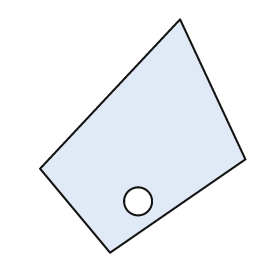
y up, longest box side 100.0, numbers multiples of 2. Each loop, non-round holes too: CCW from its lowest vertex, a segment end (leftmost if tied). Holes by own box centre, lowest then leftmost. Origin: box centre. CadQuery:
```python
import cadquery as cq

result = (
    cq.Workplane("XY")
    .moveTo(-14.0, -50.0)
    .lineTo(44.0, -10.0)
    .lineTo(16.0, 50.0)
    .lineTo(-44.0, -14.0)
    .close()
    .moveTo(-2.0, -28.0)
    .circle(6.0)
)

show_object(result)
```